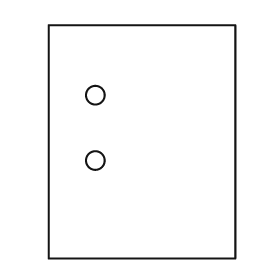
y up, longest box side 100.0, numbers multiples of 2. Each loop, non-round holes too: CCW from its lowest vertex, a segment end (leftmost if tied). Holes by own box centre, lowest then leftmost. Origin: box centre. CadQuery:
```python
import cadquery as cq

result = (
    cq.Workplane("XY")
    .moveTo(-40.0, -50.0)
    .lineTo(40.0, -50.0)
    .lineTo(40.0, 50.0)
    .lineTo(-40.0, 50.0)
    .close()
    .moveTo(-20.0, -8.0)
    .circle(4.0)
    .moveTo(-20.0, 20.0)
    .circle(4.0)
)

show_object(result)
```